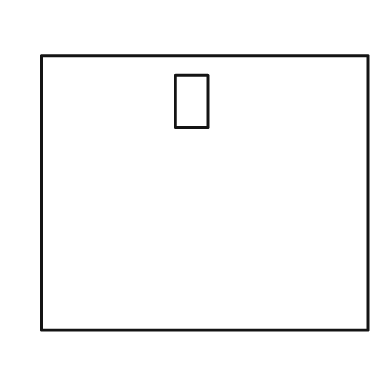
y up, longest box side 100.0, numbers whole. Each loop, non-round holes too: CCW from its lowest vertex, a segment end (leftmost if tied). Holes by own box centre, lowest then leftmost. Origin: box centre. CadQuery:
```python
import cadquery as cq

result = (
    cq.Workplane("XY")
    .moveTo(-50.0, -42.0)
    .lineTo(50.0, -42.0)
    .lineTo(50.0, 42.0)
    .lineTo(-50.0, 42.0)
    .close()
    .moveTo(-9.0, 20.0)
    .lineTo(1.0, 20.0)
    .lineTo(1.0, 36.0)
    .lineTo(-9.0, 36.0)
    .close()
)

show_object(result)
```